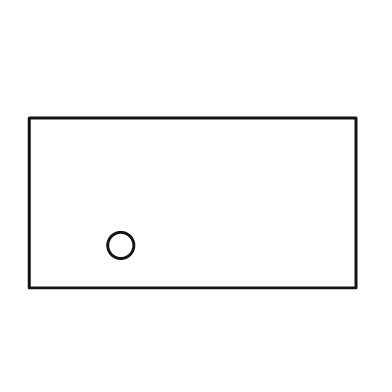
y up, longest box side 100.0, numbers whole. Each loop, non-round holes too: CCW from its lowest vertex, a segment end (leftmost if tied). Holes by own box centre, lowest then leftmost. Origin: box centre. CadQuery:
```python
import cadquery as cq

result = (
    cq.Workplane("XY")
    .moveTo(-50.0, -26.0)
    .lineTo(50.0, -26.0)
    .lineTo(50.0, 26.0)
    .lineTo(-50.0, 26.0)
    .close()
    .moveTo(-22.0, -13.0)
    .circle(4.0)
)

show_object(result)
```